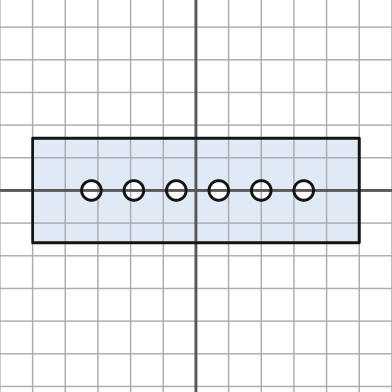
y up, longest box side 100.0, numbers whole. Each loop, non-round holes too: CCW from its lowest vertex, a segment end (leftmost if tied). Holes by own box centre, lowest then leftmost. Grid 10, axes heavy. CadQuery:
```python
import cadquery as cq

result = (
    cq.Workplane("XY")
    .moveTo(-50.0, -16.0)
    .lineTo(50.0, -16.0)
    .lineTo(50.0, 16.0)
    .lineTo(-50.0, 16.0)
    .close()
    .moveTo(-32.0, 0.0)
    .circle(3.0)
    .moveTo(-19.0, 0.0)
    .circle(3.0)
    .moveTo(-6.0, 0.0)
    .circle(3.0)
    .moveTo(7.0, 0.0)
    .circle(3.0)
    .moveTo(20.0, 0.0)
    .circle(3.0)
    .moveTo(33.0, 0.0)
    .circle(3.0)
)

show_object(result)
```